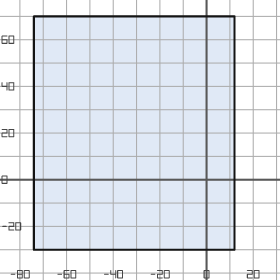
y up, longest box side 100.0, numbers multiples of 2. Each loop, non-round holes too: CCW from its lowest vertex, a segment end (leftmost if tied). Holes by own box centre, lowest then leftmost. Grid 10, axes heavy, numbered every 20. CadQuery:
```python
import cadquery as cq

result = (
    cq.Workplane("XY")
    .moveTo(-74.0, -30.0)
    .lineTo(12.0, -30.0)
    .lineTo(12.0, 70.0)
    .lineTo(-74.0, 70.0)
    .close()
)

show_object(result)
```